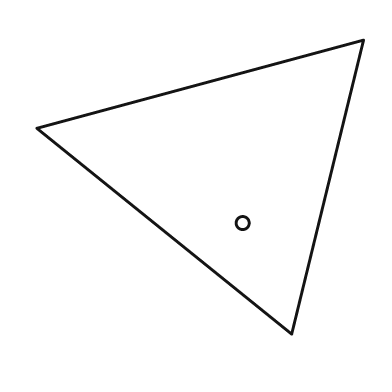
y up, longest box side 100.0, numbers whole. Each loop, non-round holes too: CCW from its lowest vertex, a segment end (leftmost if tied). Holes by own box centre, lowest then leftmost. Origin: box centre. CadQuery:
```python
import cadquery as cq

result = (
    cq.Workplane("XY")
    .moveTo(28.0, -45.0)
    .lineTo(50.0, 45.0)
    .lineTo(-50.0, 18.0)
    .close()
    .moveTo(13.0, -11.0)
    .circle(2.0)
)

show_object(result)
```